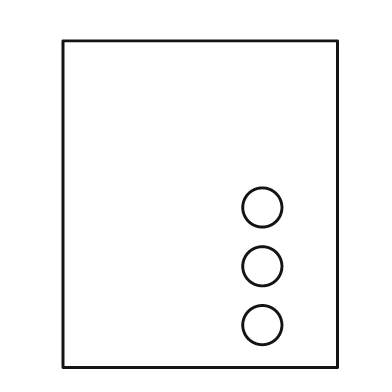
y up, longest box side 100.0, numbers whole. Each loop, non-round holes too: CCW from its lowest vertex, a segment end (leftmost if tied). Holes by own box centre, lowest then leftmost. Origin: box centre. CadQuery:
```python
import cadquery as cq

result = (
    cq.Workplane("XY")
    .moveTo(-42.0, -50.0)
    .lineTo(42.0, -50.0)
    .lineTo(42.0, 50.0)
    .lineTo(-42.0, 50.0)
    .close()
    .moveTo(19.0, -37.0)
    .circle(6.0)
    .moveTo(19.0, -19.0)
    .circle(6.0)
    .moveTo(19.0, -1.0)
    .circle(6.0)
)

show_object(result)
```